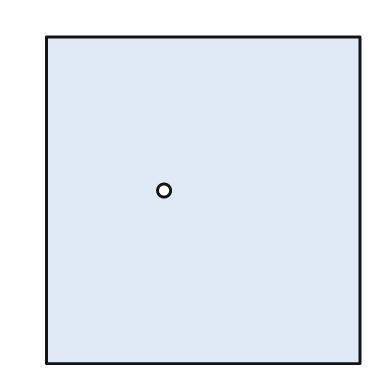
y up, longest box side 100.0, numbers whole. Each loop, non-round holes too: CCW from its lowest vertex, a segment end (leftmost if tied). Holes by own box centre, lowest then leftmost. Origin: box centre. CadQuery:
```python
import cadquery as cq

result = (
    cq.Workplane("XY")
    .moveTo(-48.0, -50.0)
    .lineTo(48.0, -50.0)
    .lineTo(48.0, 50.0)
    .lineTo(-48.0, 50.0)
    .close()
    .moveTo(-12.0, 3.0)
    .circle(2.0)
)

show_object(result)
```